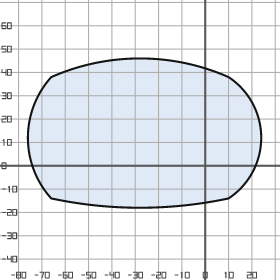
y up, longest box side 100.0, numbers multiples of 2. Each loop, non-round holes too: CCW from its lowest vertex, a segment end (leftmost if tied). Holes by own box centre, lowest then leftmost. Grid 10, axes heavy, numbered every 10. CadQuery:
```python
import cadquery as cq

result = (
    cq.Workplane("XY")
    .moveTo(-66.0, -14.0)
    .threePointArc((-28.0, -18.0), (10.0, -14.0))
    .threePointArc((24.0, 12.0), (10.0, 38.0))
    .threePointArc((-28.0, 46.0), (-66.0, 38.0))
    .threePointArc((-76.0, 12.0), (-66.0, -14.0))
    .close()
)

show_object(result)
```